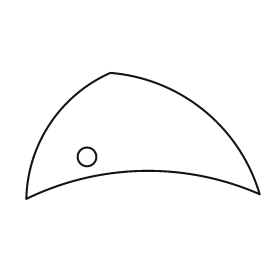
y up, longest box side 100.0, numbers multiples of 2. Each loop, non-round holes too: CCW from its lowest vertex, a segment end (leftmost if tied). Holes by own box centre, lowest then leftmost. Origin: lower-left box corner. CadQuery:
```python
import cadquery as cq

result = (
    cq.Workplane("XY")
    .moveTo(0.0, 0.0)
    .threePointArc((50.0, 12.0), (100.0, 2.0))
    .threePointArc((76.0, 38.0), (36.0, 54.0))
    .threePointArc((10.0, 32.0), (0.0, 0.0))
    .close()
    .moveTo(26.0, 18.0)
    .circle(4.0)
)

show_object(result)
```